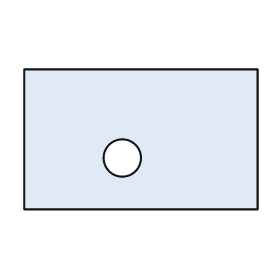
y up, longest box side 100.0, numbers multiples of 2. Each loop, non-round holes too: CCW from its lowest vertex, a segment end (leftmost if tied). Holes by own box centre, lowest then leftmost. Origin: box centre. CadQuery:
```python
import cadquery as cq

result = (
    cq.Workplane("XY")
    .moveTo(-50.0, -30.0)
    .lineTo(50.0, -30.0)
    .lineTo(50.0, 30.0)
    .lineTo(-50.0, 30.0)
    .close()
    .moveTo(-8.0, -8.0)
    .circle(8.0)
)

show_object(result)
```